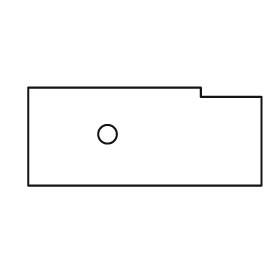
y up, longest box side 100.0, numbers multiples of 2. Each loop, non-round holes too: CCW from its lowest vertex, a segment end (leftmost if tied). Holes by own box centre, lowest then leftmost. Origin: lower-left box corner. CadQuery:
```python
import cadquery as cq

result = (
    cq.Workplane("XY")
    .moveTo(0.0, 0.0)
    .lineTo(100.0, 0.0)
    .lineTo(100.0, 38.0)
    .lineTo(74.0, 38.0)
    .lineTo(74.0, 42.0)
    .lineTo(0.0, 42.0)
    .close()
    .moveTo(34.0, 22.0)
    .circle(4.0)
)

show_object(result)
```